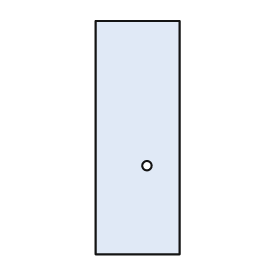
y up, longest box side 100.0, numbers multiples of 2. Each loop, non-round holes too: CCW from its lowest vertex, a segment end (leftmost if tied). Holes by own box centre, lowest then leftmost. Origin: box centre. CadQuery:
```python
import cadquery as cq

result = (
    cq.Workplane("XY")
    .moveTo(-18.0, -50.0)
    .lineTo(18.0, -50.0)
    .lineTo(18.0, 50.0)
    .lineTo(-18.0, 50.0)
    .close()
    .moveTo(4.0, -12.0)
    .circle(2.0)
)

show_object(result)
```